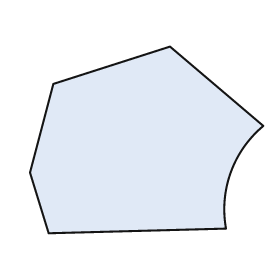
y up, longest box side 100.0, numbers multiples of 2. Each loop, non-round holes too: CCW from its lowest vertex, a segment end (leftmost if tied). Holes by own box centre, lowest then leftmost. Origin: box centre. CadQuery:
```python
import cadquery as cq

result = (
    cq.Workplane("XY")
    .moveTo(-42.0, -40.0)
    .lineTo(34.0, -38.0)
    .threePointArc((36.0, -14.0), (50.0, 6.0))
    .lineTo(10.0, 40.0)
    .lineTo(-40.0, 24.0)
    .lineTo(-50.0, -14.0)
    .close()
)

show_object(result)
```